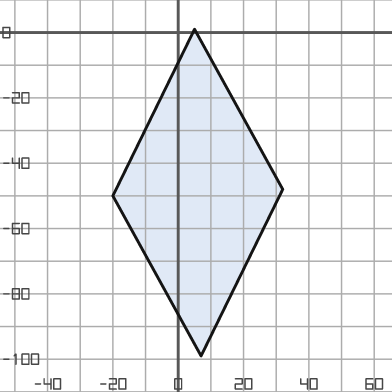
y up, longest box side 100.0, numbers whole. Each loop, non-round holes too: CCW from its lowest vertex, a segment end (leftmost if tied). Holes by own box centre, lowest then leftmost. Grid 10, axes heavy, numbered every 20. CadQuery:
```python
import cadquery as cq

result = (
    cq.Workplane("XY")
    .moveTo(7.0, -99.0)
    .lineTo(32.0, -48.0)
    .lineTo(5.0, 1.0)
    .lineTo(-20.0, -50.0)
    .close()
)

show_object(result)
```